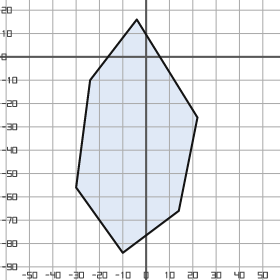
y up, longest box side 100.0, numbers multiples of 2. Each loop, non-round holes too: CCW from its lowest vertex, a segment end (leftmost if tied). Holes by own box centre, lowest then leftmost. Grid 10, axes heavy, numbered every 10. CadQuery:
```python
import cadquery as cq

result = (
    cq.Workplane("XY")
    .moveTo(-10.0, -84.0)
    .lineTo(14.0, -66.0)
    .lineTo(22.0, -26.0)
    .lineTo(-4.0, 16.0)
    .lineTo(-24.0, -10.0)
    .lineTo(-30.0, -56.0)
    .close()
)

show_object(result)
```